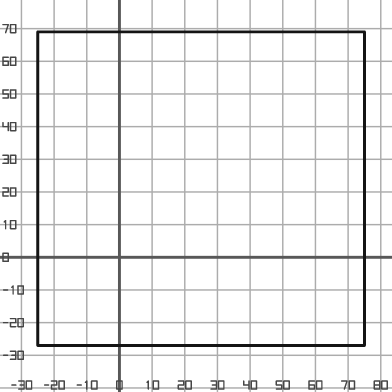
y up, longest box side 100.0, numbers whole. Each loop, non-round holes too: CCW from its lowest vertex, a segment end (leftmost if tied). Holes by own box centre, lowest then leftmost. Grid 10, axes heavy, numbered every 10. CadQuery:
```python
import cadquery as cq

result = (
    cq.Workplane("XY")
    .moveTo(-25.0, -27.0)
    .lineTo(75.0, -27.0)
    .lineTo(75.0, 69.0)
    .lineTo(-25.0, 69.0)
    .close()
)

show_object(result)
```